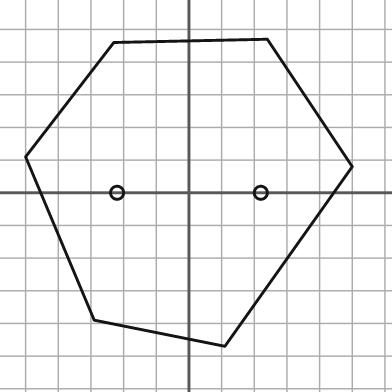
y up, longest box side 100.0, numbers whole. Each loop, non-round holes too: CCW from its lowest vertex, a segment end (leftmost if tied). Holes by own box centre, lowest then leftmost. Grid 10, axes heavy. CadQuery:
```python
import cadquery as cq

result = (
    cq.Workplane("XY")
    .moveTo(11.0, -47.0)
    .lineTo(50.0, 8.0)
    .lineTo(24.0, 47.0)
    .lineTo(-23.0, 46.0)
    .lineTo(-50.0, 11.0)
    .lineTo(-29.0, -39.0)
    .close()
    .moveTo(-22.0, 0.0)
    .circle(2.0)
    .moveTo(22.0, 0.0)
    .circle(2.0)
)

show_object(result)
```